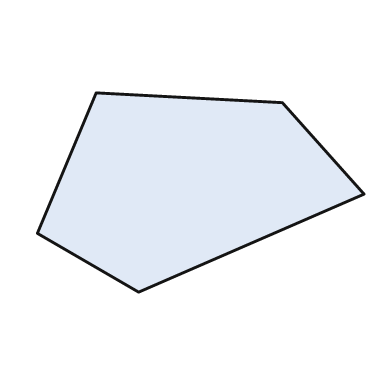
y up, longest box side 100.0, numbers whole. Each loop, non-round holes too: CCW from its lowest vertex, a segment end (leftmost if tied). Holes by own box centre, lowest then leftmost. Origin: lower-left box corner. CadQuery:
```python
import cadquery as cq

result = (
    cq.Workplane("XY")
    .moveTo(31.0, 0.0)
    .lineTo(100.0, 30.0)
    .lineTo(75.0, 58.0)
    .lineTo(18.0, 61.0)
    .lineTo(0.0, 18.0)
    .close()
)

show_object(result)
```